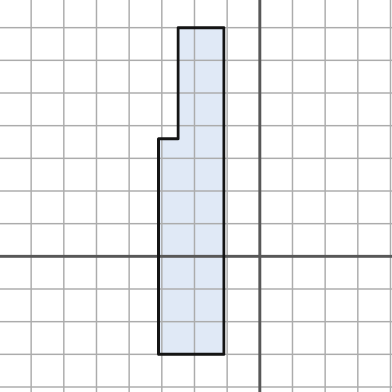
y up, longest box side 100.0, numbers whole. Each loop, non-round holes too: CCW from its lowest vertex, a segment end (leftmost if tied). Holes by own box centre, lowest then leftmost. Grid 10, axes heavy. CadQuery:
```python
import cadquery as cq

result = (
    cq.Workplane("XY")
    .moveTo(-31.0, -30.0)
    .lineTo(-11.0, -30.0)
    .lineTo(-11.0, 70.0)
    .lineTo(-25.0, 70.0)
    .lineTo(-25.0, 36.0)
    .lineTo(-31.0, 36.0)
    .close()
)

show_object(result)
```